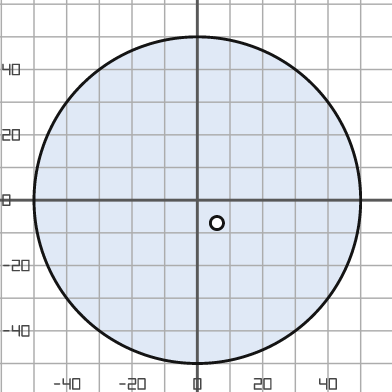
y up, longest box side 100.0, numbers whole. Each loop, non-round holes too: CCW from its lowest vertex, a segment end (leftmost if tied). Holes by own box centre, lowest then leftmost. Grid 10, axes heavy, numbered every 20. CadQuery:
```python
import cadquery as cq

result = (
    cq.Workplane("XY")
    .moveTo(0.0, 0.0)
    .circle(50.0)
    .moveTo(6.0, -7.0)
    .circle(2.0)
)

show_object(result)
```